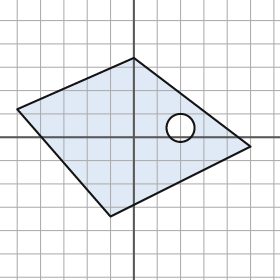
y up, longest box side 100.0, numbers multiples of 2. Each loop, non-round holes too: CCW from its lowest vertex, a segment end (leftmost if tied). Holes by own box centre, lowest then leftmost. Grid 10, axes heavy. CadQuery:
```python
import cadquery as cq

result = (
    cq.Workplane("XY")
    .moveTo(-10.0, -34.0)
    .lineTo(50.0, -4.0)
    .lineTo(0.0, 34.0)
    .lineTo(-50.0, 12.0)
    .close()
    .moveTo(20.0, 4.0)
    .circle(6.0)
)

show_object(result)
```